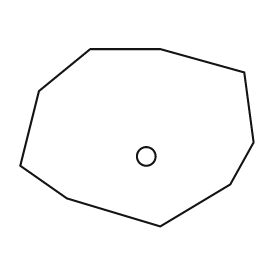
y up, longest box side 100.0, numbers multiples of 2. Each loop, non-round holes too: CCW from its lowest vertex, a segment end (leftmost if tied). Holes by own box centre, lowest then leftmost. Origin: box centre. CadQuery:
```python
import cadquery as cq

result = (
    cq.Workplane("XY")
    .moveTo(10.0, -38.0)
    .lineTo(40.0, -20.0)
    .lineTo(50.0, -2.0)
    .lineTo(46.0, 28.0)
    .lineTo(10.0, 38.0)
    .lineTo(-20.0, 38.0)
    .lineTo(-42.0, 20.0)
    .lineTo(-50.0, -12.0)
    .lineTo(-30.0, -26.0)
    .close()
    .moveTo(4.0, -8.0)
    .circle(4.0)
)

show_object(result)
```